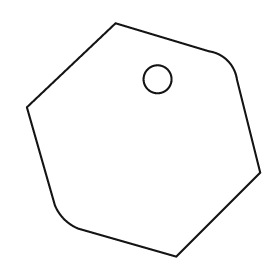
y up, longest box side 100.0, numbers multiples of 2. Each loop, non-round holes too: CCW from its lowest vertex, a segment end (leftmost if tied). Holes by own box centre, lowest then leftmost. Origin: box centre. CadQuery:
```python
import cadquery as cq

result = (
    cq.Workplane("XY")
    .moveTo(14.0, -50.0)
    .lineTo(50.0, -14.0)
    .lineTo(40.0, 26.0)
    .threePointArc((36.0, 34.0), (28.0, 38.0))
    .lineTo(-12.0, 50.0)
    .lineTo(-50.0, 14.0)
    .lineTo(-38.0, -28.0)
    .threePointArc((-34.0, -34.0), (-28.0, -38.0))
    .close()
    .moveTo(6.0, 26.0)
    .circle(6.0)
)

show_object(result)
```